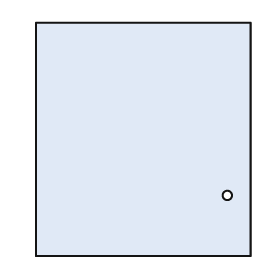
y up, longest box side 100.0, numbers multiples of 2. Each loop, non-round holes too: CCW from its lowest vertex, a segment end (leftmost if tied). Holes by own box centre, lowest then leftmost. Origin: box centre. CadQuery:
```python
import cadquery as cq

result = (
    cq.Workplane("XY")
    .moveTo(-46.0, -50.0)
    .lineTo(46.0, -50.0)
    .lineTo(46.0, 50.0)
    .lineTo(-46.0, 50.0)
    .close()
    .moveTo(36.0, -24.0)
    .circle(2.0)
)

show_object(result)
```